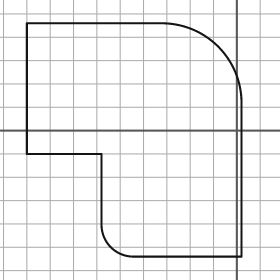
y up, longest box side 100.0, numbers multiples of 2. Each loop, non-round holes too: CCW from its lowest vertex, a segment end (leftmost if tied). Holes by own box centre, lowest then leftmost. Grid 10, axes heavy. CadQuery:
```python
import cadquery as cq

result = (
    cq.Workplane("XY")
    .moveTo(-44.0, -54.0)
    .lineTo(2.0, -54.0)
    .lineTo(2.0, 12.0)
    .threePointArc((-8.0, 36.0), (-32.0, 46.0))
    .lineTo(-90.0, 46.0)
    .lineTo(-90.0, -10.0)
    .lineTo(-58.0, -10.0)
    .lineTo(-58.0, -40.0)
    .threePointArc((-54.0, -50.0), (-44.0, -54.0))
    .close()
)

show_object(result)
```